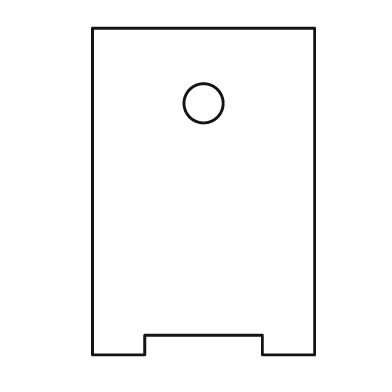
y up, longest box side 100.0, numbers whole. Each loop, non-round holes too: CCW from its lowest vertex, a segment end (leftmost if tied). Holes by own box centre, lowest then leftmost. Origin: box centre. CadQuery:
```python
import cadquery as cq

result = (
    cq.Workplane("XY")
    .moveTo(-34.0, -50.0)
    .lineTo(-18.0, -50.0)
    .lineTo(-18.0, -44.0)
    .lineTo(18.0, -44.0)
    .lineTo(18.0, -50.0)
    .lineTo(34.0, -50.0)
    .lineTo(34.0, 50.0)
    .lineTo(-34.0, 50.0)
    .close()
    .moveTo(0.0, 27.0)
    .circle(6.0)
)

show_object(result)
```